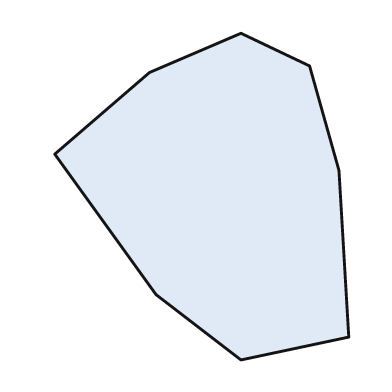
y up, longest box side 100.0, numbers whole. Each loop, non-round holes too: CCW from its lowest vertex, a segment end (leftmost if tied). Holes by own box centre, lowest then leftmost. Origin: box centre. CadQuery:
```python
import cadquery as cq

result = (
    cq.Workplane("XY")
    .moveTo(12.0, -50.0)
    .lineTo(45.0, -43.0)
    .lineTo(42.0, 8.0)
    .lineTo(33.0, 40.0)
    .lineTo(12.0, 50.0)
    .lineTo(-16.0, 38.0)
    .lineTo(-45.0, 13.0)
    .lineTo(-14.0, -30.0)
    .close()
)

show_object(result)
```